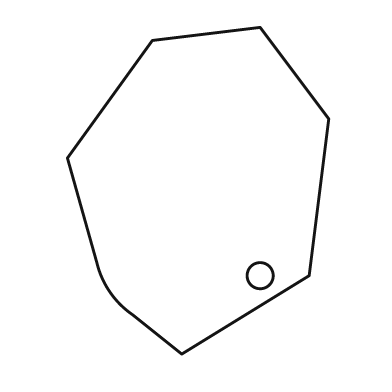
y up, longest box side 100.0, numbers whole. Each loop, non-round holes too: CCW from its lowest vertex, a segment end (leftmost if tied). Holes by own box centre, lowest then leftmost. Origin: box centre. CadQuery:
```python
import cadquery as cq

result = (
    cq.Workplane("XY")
    .moveTo(-5.0, -50.0)
    .lineTo(34.0, -26.0)
    .lineTo(40.0, 22.0)
    .lineTo(19.0, 50.0)
    .lineTo(-14.0, 46.0)
    .lineTo(-40.0, 10.0)
    .lineTo(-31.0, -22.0)
    .threePointArc((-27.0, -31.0), (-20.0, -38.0))
    .close()
    .moveTo(19.0, -26.0)
    .circle(4.0)
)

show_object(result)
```